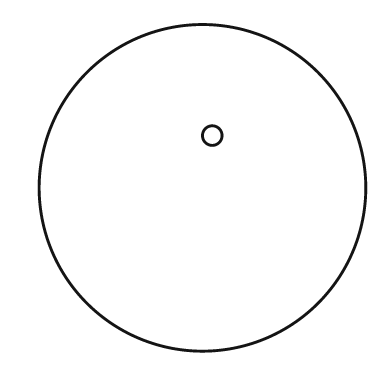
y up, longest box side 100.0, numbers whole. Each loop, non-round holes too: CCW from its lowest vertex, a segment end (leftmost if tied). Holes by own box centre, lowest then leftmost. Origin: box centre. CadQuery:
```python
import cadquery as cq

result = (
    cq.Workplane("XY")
    .moveTo(0.0, 0.0)
    .circle(50.0)
    .moveTo(3.0, 16.0)
    .circle(3.0)
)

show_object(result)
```